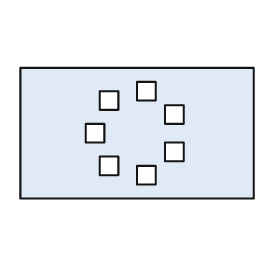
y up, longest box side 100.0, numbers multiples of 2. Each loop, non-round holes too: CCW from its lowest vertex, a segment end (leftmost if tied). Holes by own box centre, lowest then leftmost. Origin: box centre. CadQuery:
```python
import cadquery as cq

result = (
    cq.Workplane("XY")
    .moveTo(-50.0, -28.0)
    .lineTo(50.0, -28.0)
    .lineTo(50.0, 28.0)
    .lineTo(-50.0, 28.0)
    .close()
    .moveTo(0.0, -22.0)
    .lineTo(8.0, -22.0)
    .lineTo(8.0, -14.0)
    .lineTo(0.0, -14.0)
    .close()
    .moveTo(-16.0, -18.0)
    .lineTo(-8.0, -18.0)
    .lineTo(-8.0, -10.0)
    .lineTo(-16.0, -10.0)
    .close()
    .moveTo(12.0, -12.0)
    .lineTo(20.0, -12.0)
    .lineTo(20.0, -4.0)
    .lineTo(12.0, -4.0)
    .close()
    .moveTo(-22.0, -4.0)
    .lineTo(-14.0, -4.0)
    .lineTo(-14.0, 4.0)
    .lineTo(-22.0, 4.0)
    .close()
    .moveTo(12.0, 4.0)
    .lineTo(20.0, 4.0)
    .lineTo(20.0, 12.0)
    .lineTo(12.0, 12.0)
    .close()
    .moveTo(-16.0, 10.0)
    .lineTo(-8.0, 10.0)
    .lineTo(-8.0, 18.0)
    .lineTo(-16.0, 18.0)
    .close()
    .moveTo(0.0, 14.0)
    .lineTo(8.0, 14.0)
    .lineTo(8.0, 22.0)
    .lineTo(0.0, 22.0)
    .close()
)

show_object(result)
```